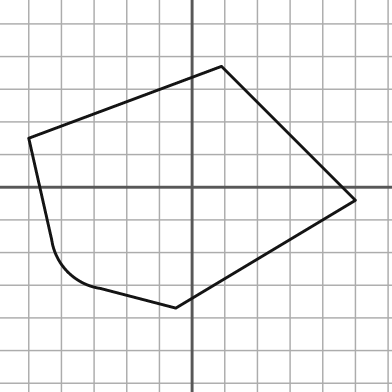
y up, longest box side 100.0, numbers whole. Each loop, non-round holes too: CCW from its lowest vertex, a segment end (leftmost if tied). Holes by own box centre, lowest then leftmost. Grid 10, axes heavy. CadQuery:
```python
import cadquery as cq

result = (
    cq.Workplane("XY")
    .moveTo(-5.0, -37.0)
    .lineTo(50.0, -4.0)
    .lineTo(9.0, 37.0)
    .lineTo(-50.0, 15.0)
    .lineTo(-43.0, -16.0)
    .threePointArc((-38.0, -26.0), (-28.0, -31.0))
    .close()
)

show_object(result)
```